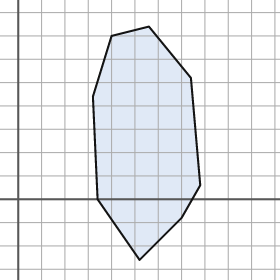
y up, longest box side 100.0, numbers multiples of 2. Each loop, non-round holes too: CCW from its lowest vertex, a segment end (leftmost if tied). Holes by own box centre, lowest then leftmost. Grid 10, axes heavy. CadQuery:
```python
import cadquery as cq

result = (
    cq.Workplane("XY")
    .moveTo(52.0, -26.0)
    .lineTo(70.0, -8.0)
    .lineTo(78.0, 6.0)
    .lineTo(74.0, 52.0)
    .lineTo(56.0, 74.0)
    .lineTo(40.0, 70.0)
    .lineTo(32.0, 44.0)
    .lineTo(34.0, 0.0)
    .close()
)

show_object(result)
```